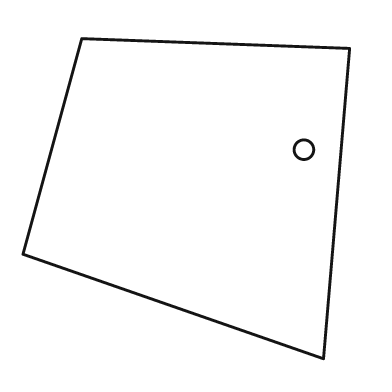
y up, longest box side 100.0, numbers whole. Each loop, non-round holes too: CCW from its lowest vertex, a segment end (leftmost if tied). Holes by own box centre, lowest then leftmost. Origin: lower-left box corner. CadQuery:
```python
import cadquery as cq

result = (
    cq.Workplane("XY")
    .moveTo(92.0, 0.0)
    .lineTo(100.0, 95.0)
    .lineTo(18.0, 98.0)
    .lineTo(0.0, 32.0)
    .close()
    .moveTo(86.0, 64.0)
    .circle(3.0)
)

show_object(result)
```